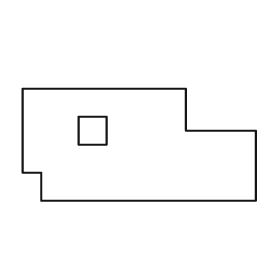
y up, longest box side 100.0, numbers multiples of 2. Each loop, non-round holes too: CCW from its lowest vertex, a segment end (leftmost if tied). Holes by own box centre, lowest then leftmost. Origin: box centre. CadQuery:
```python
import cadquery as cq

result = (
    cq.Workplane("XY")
    .moveTo(-42.0, -24.0)
    .lineTo(50.0, -24.0)
    .lineTo(50.0, 6.0)
    .lineTo(20.0, 6.0)
    .lineTo(20.0, 24.0)
    .lineTo(-50.0, 24.0)
    .lineTo(-50.0, -12.0)
    .lineTo(-42.0, -12.0)
    .close()
    .moveTo(-26.0, 0.0)
    .lineTo(-14.0, 0.0)
    .lineTo(-14.0, 12.0)
    .lineTo(-26.0, 12.0)
    .close()
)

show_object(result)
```